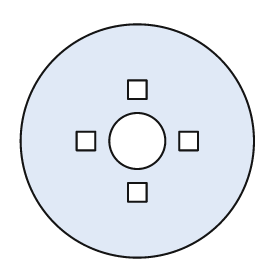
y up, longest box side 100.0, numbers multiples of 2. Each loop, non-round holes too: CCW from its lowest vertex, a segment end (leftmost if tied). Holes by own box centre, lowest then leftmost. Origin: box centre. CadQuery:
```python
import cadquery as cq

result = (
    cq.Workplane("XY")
    .moveTo(0.0, 0.0)
    .circle(50.0)
    .moveTo(-4.0, -26.0)
    .lineTo(4.0, -26.0)
    .lineTo(4.0, -18.0)
    .lineTo(-4.0, -18.0)
    .close()
    .moveTo(-26.0, -4.0)
    .lineTo(-18.0, -4.0)
    .lineTo(-18.0, 4.0)
    .lineTo(-26.0, 4.0)
    .close()
    .moveTo(0.0, 0.0)
    .circle(12.0)
    .moveTo(18.0, -4.0)
    .lineTo(26.0, -4.0)
    .lineTo(26.0, 4.0)
    .lineTo(18.0, 4.0)
    .close()
    .moveTo(-4.0, 18.0)
    .lineTo(4.0, 18.0)
    .lineTo(4.0, 26.0)
    .lineTo(-4.0, 26.0)
    .close()
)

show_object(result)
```